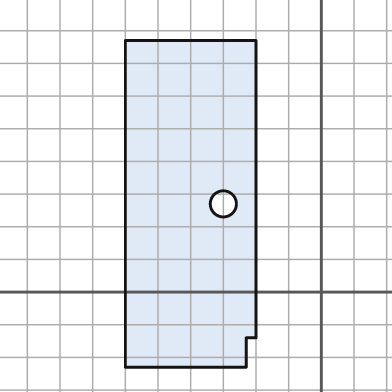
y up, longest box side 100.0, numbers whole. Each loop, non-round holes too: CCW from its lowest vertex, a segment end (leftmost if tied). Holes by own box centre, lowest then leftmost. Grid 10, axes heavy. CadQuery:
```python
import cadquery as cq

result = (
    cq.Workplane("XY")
    .moveTo(-60.0, -23.0)
    .lineTo(-23.0, -23.0)
    .lineTo(-23.0, -14.0)
    .lineTo(-20.0, -14.0)
    .lineTo(-20.0, 77.0)
    .lineTo(-60.0, 77.0)
    .close()
    .moveTo(-30.0, 27.0)
    .circle(4.0)
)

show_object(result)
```